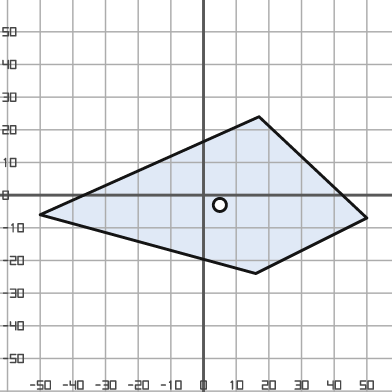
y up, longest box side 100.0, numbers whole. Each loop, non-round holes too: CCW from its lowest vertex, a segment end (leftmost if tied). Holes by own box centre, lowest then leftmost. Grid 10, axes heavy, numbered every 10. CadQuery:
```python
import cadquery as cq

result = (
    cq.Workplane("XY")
    .moveTo(16.0, -24.0)
    .lineTo(50.0, -7.0)
    .lineTo(17.0, 24.0)
    .lineTo(-50.0, -6.0)
    .close()
    .moveTo(5.0, -3.0)
    .circle(2.0)
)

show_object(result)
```